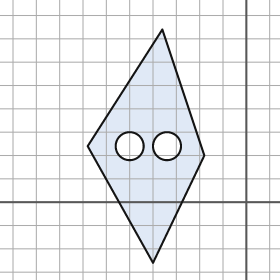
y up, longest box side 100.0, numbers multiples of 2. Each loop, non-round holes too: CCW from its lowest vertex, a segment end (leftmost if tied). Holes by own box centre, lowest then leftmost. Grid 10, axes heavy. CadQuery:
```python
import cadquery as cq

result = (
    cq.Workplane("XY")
    .moveTo(-40.0, -26.0)
    .lineTo(-18.0, 20.0)
    .lineTo(-36.0, 74.0)
    .lineTo(-68.0, 24.0)
    .close()
    .moveTo(-50.0, 24.0)
    .circle(6.0)
    .moveTo(-34.0, 24.0)
    .circle(6.0)
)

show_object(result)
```